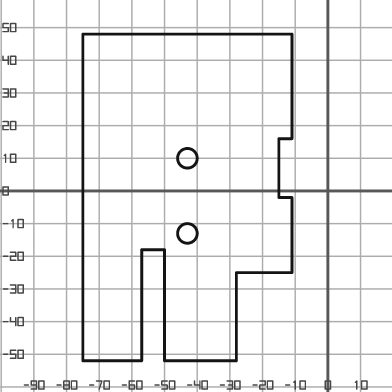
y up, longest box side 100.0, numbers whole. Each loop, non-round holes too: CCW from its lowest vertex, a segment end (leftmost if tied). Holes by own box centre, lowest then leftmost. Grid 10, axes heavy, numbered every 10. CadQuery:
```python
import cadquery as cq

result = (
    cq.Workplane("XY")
    .moveTo(-75.0, -52.0)
    .lineTo(-57.0, -52.0)
    .lineTo(-57.0, -18.0)
    .lineTo(-50.0, -18.0)
    .lineTo(-50.0, -52.0)
    .lineTo(-28.0, -52.0)
    .lineTo(-28.0, -25.0)
    .lineTo(-11.0, -25.0)
    .lineTo(-11.0, -2.0)
    .lineTo(-15.0, -2.0)
    .lineTo(-15.0, 16.0)
    .lineTo(-11.0, 16.0)
    .lineTo(-11.0, 48.0)
    .lineTo(-75.0, 48.0)
    .close()
    .moveTo(-43.0, -13.0)
    .circle(3.0)
    .moveTo(-43.0, 10.0)
    .circle(3.0)
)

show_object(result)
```